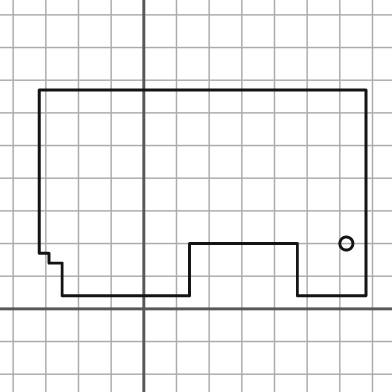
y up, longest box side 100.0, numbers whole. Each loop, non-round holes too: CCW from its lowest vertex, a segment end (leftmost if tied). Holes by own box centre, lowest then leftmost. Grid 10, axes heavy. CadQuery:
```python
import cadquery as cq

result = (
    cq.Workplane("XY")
    .moveTo(-25.0, 4.0)
    .lineTo(14.0, 4.0)
    .lineTo(14.0, 20.0)
    .lineTo(47.0, 20.0)
    .lineTo(47.0, 4.0)
    .lineTo(68.0, 4.0)
    .lineTo(68.0, 67.0)
    .lineTo(-32.0, 67.0)
    .lineTo(-32.0, 17.0)
    .lineTo(-29.0, 17.0)
    .lineTo(-29.0, 14.0)
    .lineTo(-25.0, 14.0)
    .close()
    .moveTo(62.0, 20.0)
    .circle(2.0)
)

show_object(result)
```